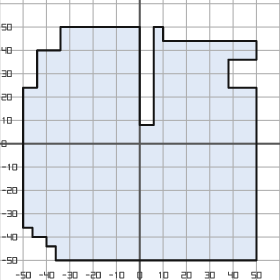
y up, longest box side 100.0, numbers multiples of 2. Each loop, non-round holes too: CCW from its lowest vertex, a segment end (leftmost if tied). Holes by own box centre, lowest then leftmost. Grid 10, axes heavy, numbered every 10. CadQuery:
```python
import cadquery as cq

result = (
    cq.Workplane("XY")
    .moveTo(-36.0, -50.0)
    .lineTo(50.0, -50.0)
    .lineTo(50.0, 24.0)
    .lineTo(38.0, 24.0)
    .lineTo(38.0, 36.0)
    .lineTo(50.0, 36.0)
    .lineTo(50.0, 44.0)
    .lineTo(10.0, 44.0)
    .lineTo(10.0, 50.0)
    .lineTo(6.0, 50.0)
    .lineTo(6.0, 8.0)
    .lineTo(0.0, 8.0)
    .lineTo(0.0, 50.0)
    .lineTo(-34.0, 50.0)
    .lineTo(-34.0, 40.0)
    .lineTo(-44.0, 40.0)
    .lineTo(-44.0, 24.0)
    .lineTo(-50.0, 24.0)
    .lineTo(-50.0, -36.0)
    .lineTo(-46.0, -36.0)
    .lineTo(-46.0, -40.0)
    .lineTo(-40.0, -40.0)
    .lineTo(-40.0, -44.0)
    .lineTo(-36.0, -44.0)
    .close()
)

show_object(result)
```